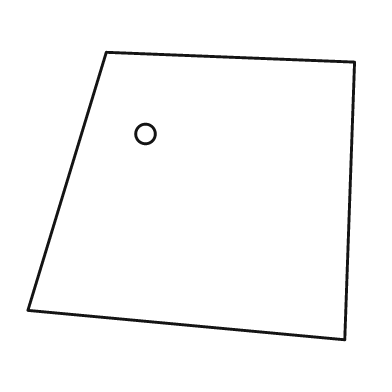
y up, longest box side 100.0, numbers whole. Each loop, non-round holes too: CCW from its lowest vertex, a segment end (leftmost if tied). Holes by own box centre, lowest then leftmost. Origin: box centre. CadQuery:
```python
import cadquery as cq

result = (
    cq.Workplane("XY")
    .moveTo(47.0, -44.0)
    .lineTo(50.0, 41.0)
    .lineTo(-26.0, 44.0)
    .lineTo(-50.0, -35.0)
    .close()
    .moveTo(-14.0, 19.0)
    .circle(3.0)
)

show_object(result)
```